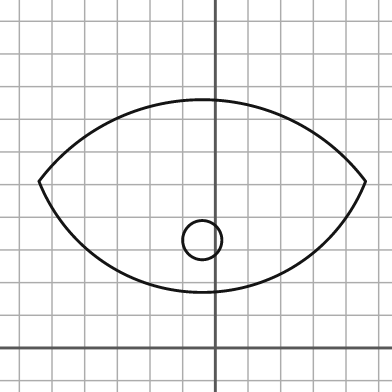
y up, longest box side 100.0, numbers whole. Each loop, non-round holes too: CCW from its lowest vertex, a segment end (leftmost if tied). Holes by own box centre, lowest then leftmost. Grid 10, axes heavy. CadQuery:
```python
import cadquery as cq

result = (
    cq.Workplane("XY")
    .moveTo(-54.0, 51.0)
    .threePointArc((-4.0, 17.0), (46.0, 51.0))
    .threePointArc((-4.0, 76.0), (-54.0, 51.0))
    .close()
    .moveTo(-4.0, 33.0)
    .circle(6.0)
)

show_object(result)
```